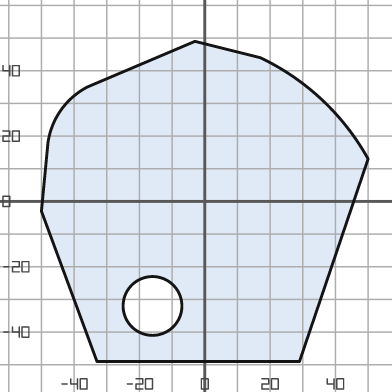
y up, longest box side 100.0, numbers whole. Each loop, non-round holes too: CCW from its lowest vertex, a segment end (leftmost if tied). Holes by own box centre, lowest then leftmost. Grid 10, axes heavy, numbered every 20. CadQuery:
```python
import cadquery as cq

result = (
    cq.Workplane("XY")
    .moveTo(-33.0, -49.0)
    .lineTo(29.0, -49.0)
    .lineTo(50.0, 13.0)
    .threePointArc((36.0, 31.0), (17.0, 44.0))
    .lineTo(-3.0, 49.0)
    .lineTo(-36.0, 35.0)
    .threePointArc((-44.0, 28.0), (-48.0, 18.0))
    .lineTo(-50.0, -3.0)
    .close()
    .moveTo(-16.0, -32.0)
    .circle(9.0)
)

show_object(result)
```